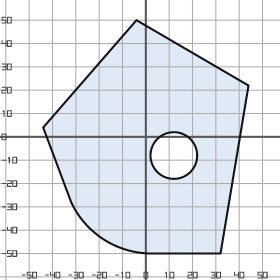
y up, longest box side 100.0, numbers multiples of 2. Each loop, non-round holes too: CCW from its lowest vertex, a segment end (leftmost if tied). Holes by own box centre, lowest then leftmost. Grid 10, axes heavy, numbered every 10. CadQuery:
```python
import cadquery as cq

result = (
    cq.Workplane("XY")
    .moveTo(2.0, -50.0)
    .lineTo(32.0, -50.0)
    .lineTo(44.0, 22.0)
    .lineTo(-4.0, 50.0)
    .lineTo(-44.0, 4.0)
    .lineTo(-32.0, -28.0)
    .threePointArc((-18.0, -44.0), (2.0, -50.0))
    .close()
    .moveTo(12.0, -8.0)
    .circle(10.0)
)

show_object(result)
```